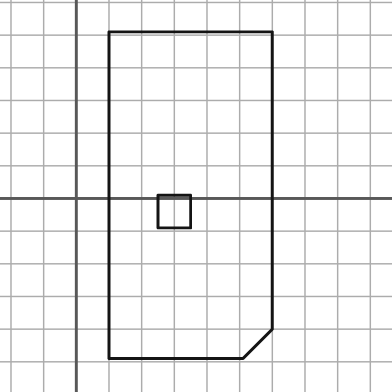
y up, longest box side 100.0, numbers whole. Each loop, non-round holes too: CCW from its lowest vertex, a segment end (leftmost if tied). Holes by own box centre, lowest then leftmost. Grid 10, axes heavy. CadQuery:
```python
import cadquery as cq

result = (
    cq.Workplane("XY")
    .moveTo(10.0, -49.0)
    .lineTo(51.0, -49.0)
    .lineTo(60.0, -40.0)
    .lineTo(60.0, 51.0)
    .lineTo(10.0, 51.0)
    .close()
    .moveTo(25.0, -9.0)
    .lineTo(35.0, -9.0)
    .lineTo(35.0, 1.0)
    .lineTo(25.0, 1.0)
    .close()
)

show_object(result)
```